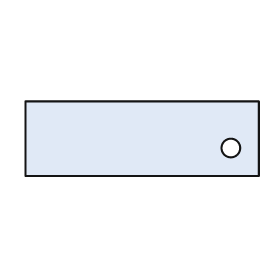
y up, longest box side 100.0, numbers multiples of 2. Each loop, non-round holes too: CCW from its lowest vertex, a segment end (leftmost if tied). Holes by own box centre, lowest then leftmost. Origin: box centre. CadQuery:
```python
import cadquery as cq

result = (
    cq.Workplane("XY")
    .moveTo(-50.0, -16.0)
    .lineTo(50.0, -16.0)
    .lineTo(50.0, 16.0)
    .lineTo(-50.0, 16.0)
    .close()
    .moveTo(38.0, -4.0)
    .circle(4.0)
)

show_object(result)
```